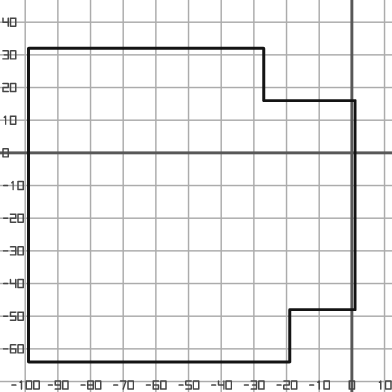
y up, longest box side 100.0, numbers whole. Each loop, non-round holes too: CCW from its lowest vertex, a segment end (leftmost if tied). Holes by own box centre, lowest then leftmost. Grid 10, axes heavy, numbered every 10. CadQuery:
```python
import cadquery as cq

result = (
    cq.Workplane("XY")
    .moveTo(-99.0, -64.0)
    .lineTo(-19.0, -64.0)
    .lineTo(-19.0, -48.0)
    .lineTo(1.0, -48.0)
    .lineTo(1.0, 16.0)
    .lineTo(-27.0, 16.0)
    .lineTo(-27.0, 32.0)
    .lineTo(-99.0, 32.0)
    .close()
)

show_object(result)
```